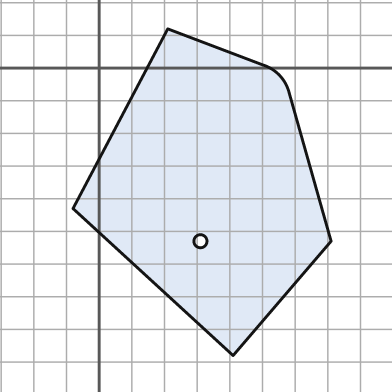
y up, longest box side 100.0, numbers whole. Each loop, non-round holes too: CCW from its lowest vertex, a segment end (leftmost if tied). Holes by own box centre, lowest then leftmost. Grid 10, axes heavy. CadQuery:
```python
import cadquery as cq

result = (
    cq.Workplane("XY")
    .moveTo(41.0, -88.0)
    .lineTo(71.0, -53.0)
    .lineTo(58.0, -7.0)
    .threePointArc((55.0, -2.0), (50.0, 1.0))
    .lineTo(21.0, 12.0)
    .lineTo(-8.0, -43.0)
    .close()
    .moveTo(31.0, -53.0)
    .circle(2.0)
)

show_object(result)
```